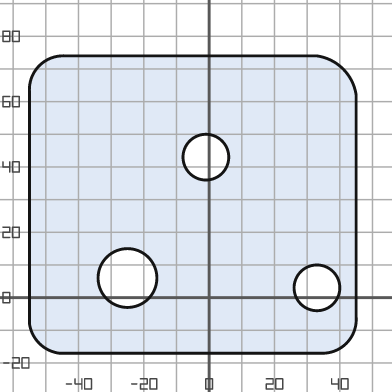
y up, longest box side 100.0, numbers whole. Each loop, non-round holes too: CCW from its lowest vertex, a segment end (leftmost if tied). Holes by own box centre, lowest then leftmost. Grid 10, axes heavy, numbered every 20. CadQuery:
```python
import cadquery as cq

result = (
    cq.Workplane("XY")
    .moveTo(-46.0, -17.0)
    .lineTo(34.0, -17.0)
    .threePointArc((42.0, -14.0), (45.0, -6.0))
    .lineTo(45.0, 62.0)
    .threePointArc((41.0, 70.0), (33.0, 74.0))
    .lineTo(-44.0, 74.0)
    .threePointArc((-52.0, 71.0), (-55.0, 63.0))
    .lineTo(-55.0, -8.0)
    .threePointArc((-52.0, -14.0), (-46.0, -17.0))
    .close()
    .moveTo(33.0, 3.0)
    .circle(7.0)
    .moveTo(-25.0, 6.0)
    .circle(9.0)
    .moveTo(-1.0, 43.0)
    .circle(7.0)
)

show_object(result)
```